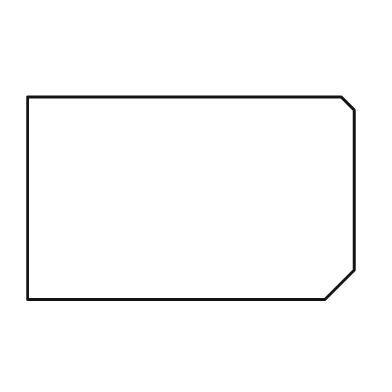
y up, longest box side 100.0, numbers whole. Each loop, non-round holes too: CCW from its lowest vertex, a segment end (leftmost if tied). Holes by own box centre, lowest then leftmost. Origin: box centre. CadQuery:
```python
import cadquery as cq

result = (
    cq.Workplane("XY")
    .moveTo(-50.0, -31.0)
    .lineTo(41.0, -31.0)
    .lineTo(50.0, -22.0)
    .lineTo(50.0, 27.0)
    .lineTo(46.0, 31.0)
    .lineTo(-50.0, 31.0)
    .close()
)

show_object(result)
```